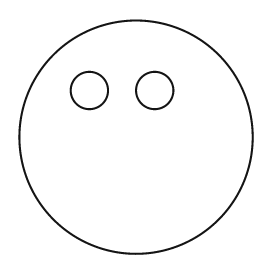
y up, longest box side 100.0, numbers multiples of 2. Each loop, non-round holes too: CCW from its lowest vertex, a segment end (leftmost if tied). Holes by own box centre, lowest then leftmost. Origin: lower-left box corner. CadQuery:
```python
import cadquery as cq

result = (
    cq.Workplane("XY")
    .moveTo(50.0, 50.0)
    .circle(50.0)
    .moveTo(30.0, 70.0)
    .circle(8.0)
    .moveTo(58.0, 70.0)
    .circle(8.0)
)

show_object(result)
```